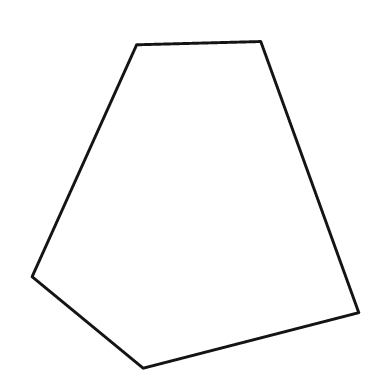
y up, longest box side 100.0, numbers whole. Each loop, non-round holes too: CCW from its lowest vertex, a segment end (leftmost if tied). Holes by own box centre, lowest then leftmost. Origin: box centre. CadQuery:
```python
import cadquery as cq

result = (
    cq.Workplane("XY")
    .moveTo(-16.0, -50.0)
    .lineTo(50.0, -33.0)
    .lineTo(20.0, 50.0)
    .lineTo(-18.0, 49.0)
    .lineTo(-50.0, -22.0)
    .close()
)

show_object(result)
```